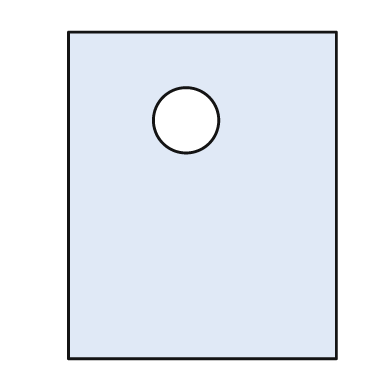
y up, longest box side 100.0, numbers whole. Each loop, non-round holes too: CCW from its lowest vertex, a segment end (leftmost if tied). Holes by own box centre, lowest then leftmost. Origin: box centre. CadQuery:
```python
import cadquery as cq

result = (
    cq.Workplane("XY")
    .moveTo(-41.0, -50.0)
    .lineTo(41.0, -50.0)
    .lineTo(41.0, 50.0)
    .lineTo(-41.0, 50.0)
    .close()
    .moveTo(-5.0, 23.0)
    .circle(10.0)
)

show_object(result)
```